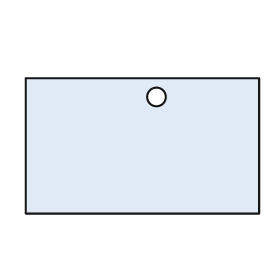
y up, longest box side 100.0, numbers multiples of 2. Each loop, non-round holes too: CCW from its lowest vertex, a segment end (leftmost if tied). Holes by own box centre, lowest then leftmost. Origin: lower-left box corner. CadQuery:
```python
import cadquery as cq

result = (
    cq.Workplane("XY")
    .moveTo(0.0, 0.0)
    .lineTo(100.0, 0.0)
    .lineTo(100.0, 58.0)
    .lineTo(0.0, 58.0)
    .close()
    .moveTo(56.0, 50.0)
    .circle(4.0)
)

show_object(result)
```